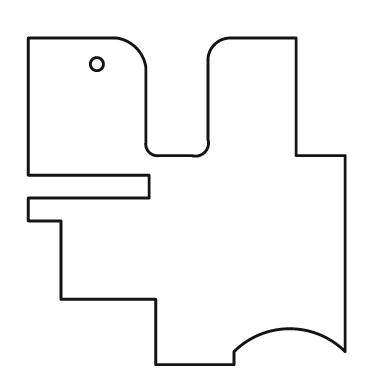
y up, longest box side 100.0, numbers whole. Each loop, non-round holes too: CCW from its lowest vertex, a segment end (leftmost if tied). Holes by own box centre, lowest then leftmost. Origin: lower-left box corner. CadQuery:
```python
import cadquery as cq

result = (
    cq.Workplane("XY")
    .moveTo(39.0, 0.0)
    .lineTo(63.0, 0.0)
    .lineTo(63.0, 4.0)
    .threePointArc((80.0, 11.0), (97.0, 4.0))
    .lineTo(97.0, 64.0)
    .lineTo(82.0, 64.0)
    .lineTo(82.0, 100.0)
    .lineTo(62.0, 100.0)
    .threePointArc((57.0, 98.0), (55.0, 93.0))
    .lineTo(55.0, 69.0)
    .threePointArc((54.0, 65.0), (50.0, 64.0))
    .lineTo(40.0, 64.0)
    .threePointArc((37.0, 65.0), (36.0, 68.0))
    .lineTo(36.0, 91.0)
    .threePointArc((33.0, 97.0), (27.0, 100.0))
    .lineTo(0.0, 100.0)
    .lineTo(0.0, 58.0)
    .lineTo(37.0, 58.0)
    .lineTo(37.0, 51.0)
    .lineTo(0.0, 51.0)
    .lineTo(0.0, 44.0)
    .lineTo(10.0, 44.0)
    .lineTo(10.0, 20.0)
    .lineTo(39.0, 20.0)
    .close()
    .moveTo(21.0, 92.0)
    .circle(2.0)
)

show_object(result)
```